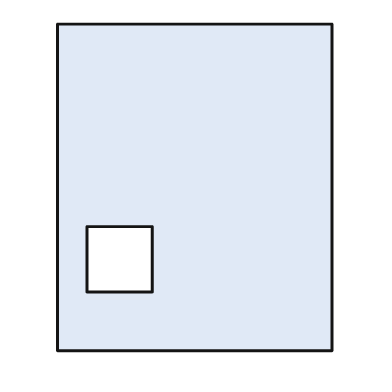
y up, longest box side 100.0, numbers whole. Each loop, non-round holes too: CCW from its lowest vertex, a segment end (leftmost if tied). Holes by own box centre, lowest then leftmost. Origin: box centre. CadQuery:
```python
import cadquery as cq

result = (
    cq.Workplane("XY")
    .moveTo(-42.0, -50.0)
    .lineTo(42.0, -50.0)
    .lineTo(42.0, 50.0)
    .lineTo(-42.0, 50.0)
    .close()
    .moveTo(-33.0, -32.0)
    .lineTo(-13.0, -32.0)
    .lineTo(-13.0, -12.0)
    .lineTo(-33.0, -12.0)
    .close()
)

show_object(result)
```